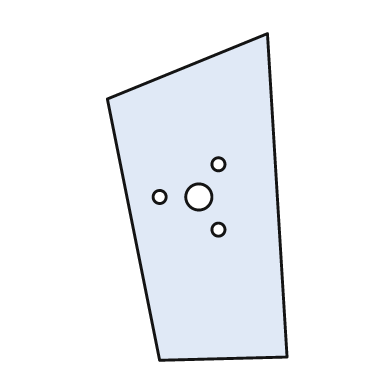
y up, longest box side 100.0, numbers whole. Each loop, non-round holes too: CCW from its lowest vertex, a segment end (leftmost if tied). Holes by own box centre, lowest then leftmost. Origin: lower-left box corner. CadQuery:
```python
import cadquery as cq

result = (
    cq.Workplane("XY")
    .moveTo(16.0, 0.0)
    .lineTo(55.0, 1.0)
    .lineTo(49.0, 100.0)
    .lineTo(0.0, 80.0)
    .close()
    .moveTo(34.0, 40.0)
    .circle(2.0)
    .moveTo(16.0, 50.0)
    .circle(2.0)
    .moveTo(28.0, 50.0)
    .circle(4.0)
    .moveTo(34.0, 60.0)
    .circle(2.0)
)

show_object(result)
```